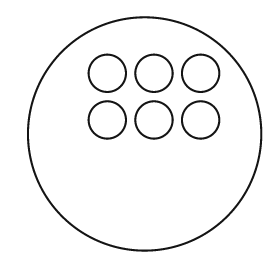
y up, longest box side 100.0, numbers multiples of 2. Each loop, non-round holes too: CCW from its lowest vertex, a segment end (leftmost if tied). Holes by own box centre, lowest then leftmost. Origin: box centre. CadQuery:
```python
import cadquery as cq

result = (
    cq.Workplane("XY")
    .moveTo(0.0, 0.0)
    .circle(50.0)
    .moveTo(-16.0, 6.0)
    .circle(8.0)
    .moveTo(4.0, 6.0)
    .circle(8.0)
    .moveTo(24.0, 6.0)
    .circle(8.0)
    .moveTo(-16.0, 26.0)
    .circle(8.0)
    .moveTo(4.0, 26.0)
    .circle(8.0)
    .moveTo(24.0, 26.0)
    .circle(8.0)
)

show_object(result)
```